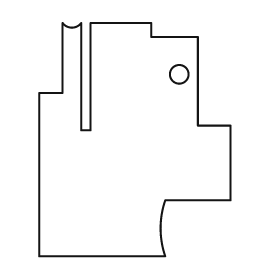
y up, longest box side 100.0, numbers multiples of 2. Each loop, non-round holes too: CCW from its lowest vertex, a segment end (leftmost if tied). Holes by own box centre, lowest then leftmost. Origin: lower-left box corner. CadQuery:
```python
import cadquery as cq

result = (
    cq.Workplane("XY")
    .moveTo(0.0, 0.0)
    .lineTo(54.0, 0.0)
    .threePointArc((52.0, 12.0), (54.0, 24.0))
    .lineTo(82.0, 24.0)
    .lineTo(82.0, 56.0)
    .lineTo(68.0, 56.0)
    .lineTo(68.0, 94.0)
    .lineTo(48.0, 94.0)
    .lineTo(48.0, 100.0)
    .lineTo(22.0, 100.0)
    .lineTo(22.0, 54.0)
    .lineTo(18.0, 54.0)
    .lineTo(18.0, 100.0)
    .threePointArc((14.0, 98.0), (10.0, 100.0))
    .lineTo(10.0, 70.0)
    .lineTo(0.0, 70.0)
    .close()
    .moveTo(60.0, 78.0)
    .circle(4.0)
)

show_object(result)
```